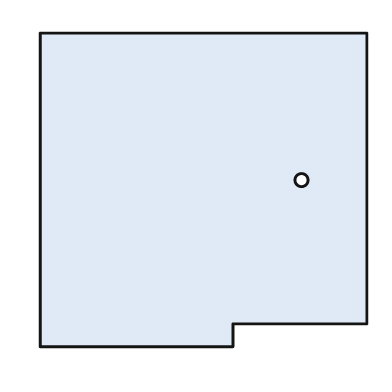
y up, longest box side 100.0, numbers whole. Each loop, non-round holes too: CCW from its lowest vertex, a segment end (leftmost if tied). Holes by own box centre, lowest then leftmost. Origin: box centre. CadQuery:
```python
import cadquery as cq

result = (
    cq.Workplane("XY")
    .moveTo(-50.0, -48.0)
    .lineTo(9.0, -48.0)
    .lineTo(9.0, -41.0)
    .lineTo(50.0, -41.0)
    .lineTo(50.0, 48.0)
    .lineTo(-50.0, 48.0)
    .close()
    .moveTo(30.0, 3.0)
    .circle(2.0)
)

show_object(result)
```